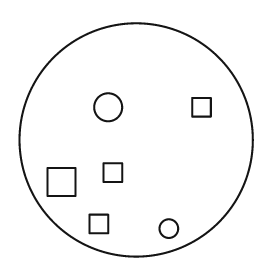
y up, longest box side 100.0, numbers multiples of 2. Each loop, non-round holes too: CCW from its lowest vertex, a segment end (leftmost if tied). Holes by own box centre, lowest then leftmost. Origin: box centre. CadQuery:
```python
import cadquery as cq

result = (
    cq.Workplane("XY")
    .moveTo(0.0, 0.0)
    .circle(50.0)
    .moveTo(14.0, -38.0)
    .circle(4.0)
    .moveTo(-20.0, -40.0)
    .lineTo(-12.0, -40.0)
    .lineTo(-12.0, -32.0)
    .lineTo(-20.0, -32.0)
    .close()
    .moveTo(-38.0, -24.0)
    .lineTo(-26.0, -24.0)
    .lineTo(-26.0, -12.0)
    .lineTo(-38.0, -12.0)
    .close()
    .moveTo(-14.0, -18.0)
    .lineTo(-6.0, -18.0)
    .lineTo(-6.0, -10.0)
    .lineTo(-14.0, -10.0)
    .close()
    .moveTo(-12.0, 14.0)
    .circle(6.0)
    .moveTo(24.0, 10.0)
    .lineTo(32.0, 10.0)
    .lineTo(32.0, 18.0)
    .lineTo(24.0, 18.0)
    .close()
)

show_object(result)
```